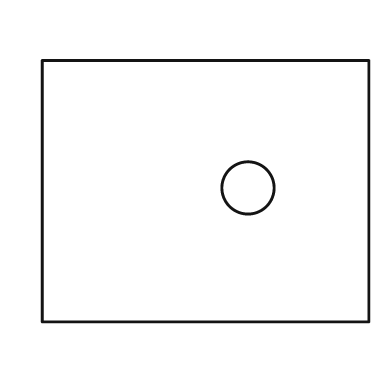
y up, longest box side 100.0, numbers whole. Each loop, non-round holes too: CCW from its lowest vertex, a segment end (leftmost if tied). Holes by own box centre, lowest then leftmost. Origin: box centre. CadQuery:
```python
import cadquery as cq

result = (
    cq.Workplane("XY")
    .moveTo(-50.0, -40.0)
    .lineTo(50.0, -40.0)
    .lineTo(50.0, 40.0)
    .lineTo(-50.0, 40.0)
    .close()
    .moveTo(13.0, 1.0)
    .circle(8.0)
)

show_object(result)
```